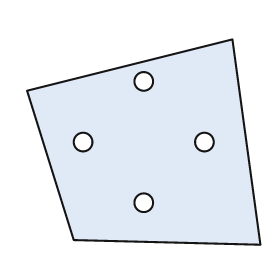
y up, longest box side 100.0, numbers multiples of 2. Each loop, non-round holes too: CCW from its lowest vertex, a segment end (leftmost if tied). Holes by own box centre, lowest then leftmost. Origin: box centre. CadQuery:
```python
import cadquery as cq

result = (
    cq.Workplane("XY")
    .moveTo(50.0, -44.0)
    .lineTo(38.0, 44.0)
    .lineTo(-50.0, 22.0)
    .lineTo(-30.0, -42.0)
    .close()
    .moveTo(0.0, -26.0)
    .circle(4.0)
    .moveTo(-26.0, 0.0)
    .circle(4.0)
    .moveTo(26.0, 0.0)
    .circle(4.0)
    .moveTo(0.0, 26.0)
    .circle(4.0)
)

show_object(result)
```